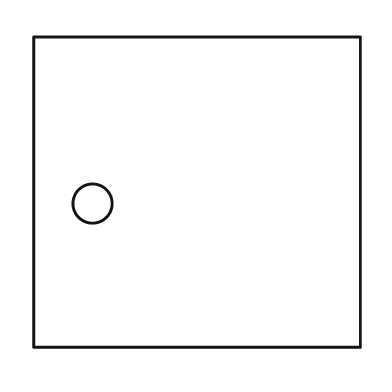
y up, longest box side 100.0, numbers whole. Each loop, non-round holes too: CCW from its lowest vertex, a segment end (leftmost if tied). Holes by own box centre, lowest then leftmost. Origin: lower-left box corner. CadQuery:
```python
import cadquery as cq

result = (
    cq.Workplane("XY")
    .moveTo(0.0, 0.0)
    .lineTo(100.0, 0.0)
    .lineTo(100.0, 95.0)
    .lineTo(0.0, 95.0)
    .close()
    .moveTo(18.0, 44.0)
    .circle(6.0)
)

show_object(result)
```